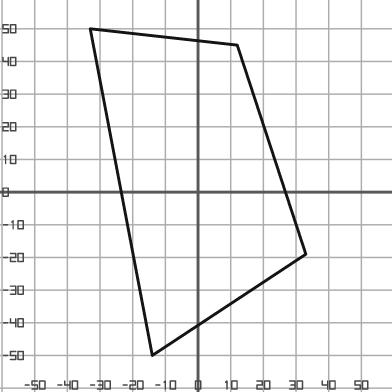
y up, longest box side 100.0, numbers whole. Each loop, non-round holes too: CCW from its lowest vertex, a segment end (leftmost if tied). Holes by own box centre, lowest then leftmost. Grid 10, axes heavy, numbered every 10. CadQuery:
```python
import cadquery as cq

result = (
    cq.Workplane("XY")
    .moveTo(-14.0, -50.0)
    .lineTo(33.0, -19.0)
    .lineTo(12.0, 45.0)
    .lineTo(-33.0, 50.0)
    .close()
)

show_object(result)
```